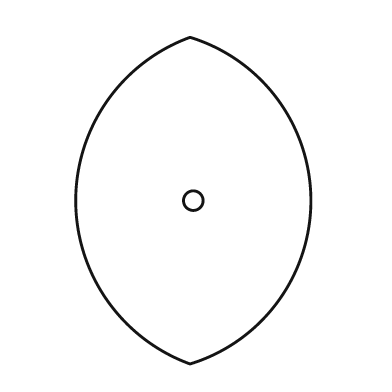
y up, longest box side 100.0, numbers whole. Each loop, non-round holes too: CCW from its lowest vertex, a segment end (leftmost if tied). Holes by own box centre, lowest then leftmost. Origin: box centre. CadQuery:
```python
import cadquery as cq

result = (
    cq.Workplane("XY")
    .moveTo(-1.0, -50.0)
    .threePointArc((36.0, 0.0), (-1.0, 50.0))
    .threePointArc((-36.0, 0.0), (-1.0, -50.0))
    .close()
    .moveTo(0.0, 0.0)
    .circle(3.0)
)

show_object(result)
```